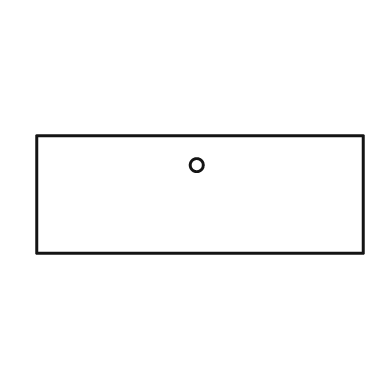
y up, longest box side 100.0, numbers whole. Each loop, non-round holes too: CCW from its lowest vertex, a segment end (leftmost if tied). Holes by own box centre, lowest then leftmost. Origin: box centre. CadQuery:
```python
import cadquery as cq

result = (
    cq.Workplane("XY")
    .moveTo(-50.0, -18.0)
    .lineTo(50.0, -18.0)
    .lineTo(50.0, 18.0)
    .lineTo(-50.0, 18.0)
    .close()
    .moveTo(-1.0, 9.0)
    .circle(2.0)
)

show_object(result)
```